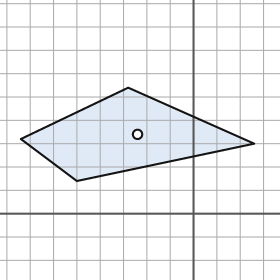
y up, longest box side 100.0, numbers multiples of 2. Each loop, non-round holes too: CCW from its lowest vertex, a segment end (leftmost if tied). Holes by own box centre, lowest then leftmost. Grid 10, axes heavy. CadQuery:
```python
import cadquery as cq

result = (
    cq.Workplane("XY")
    .moveTo(-50.0, 14.0)
    .lineTo(26.0, 30.0)
    .lineTo(-28.0, 54.0)
    .lineTo(-74.0, 32.0)
    .close()
    .moveTo(-24.0, 34.0)
    .circle(2.0)
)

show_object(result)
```